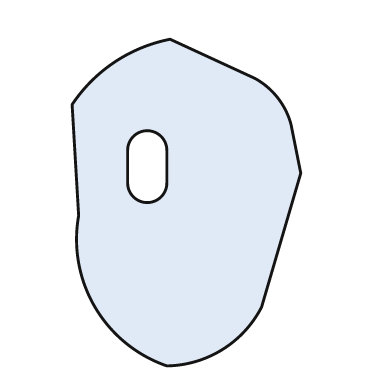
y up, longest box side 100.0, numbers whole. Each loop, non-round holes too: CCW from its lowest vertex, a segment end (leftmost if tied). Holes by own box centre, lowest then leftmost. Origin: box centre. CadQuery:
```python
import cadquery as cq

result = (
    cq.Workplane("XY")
    .moveTo(-6.0, -50.0)
    .threePointArc((11.0, -45.0), (23.0, -32.0))
    .lineTo(35.0, 9.0)
    .lineTo(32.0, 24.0)
    .threePointArc((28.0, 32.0), (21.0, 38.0))
    .lineTo(-5.0, 50.0)
    .threePointArc((-22.0, 43.0), (-35.0, 30.0))
    .lineTo(-33.0, -4.0)
    .threePointArc((-28.0, -32.0), (-6.0, -50.0))
    .close()
    .moveTo(-18.0, 6.0)
    .threePointArc((-12.0, 0.0), (-6.0, 6.0))
    .lineTo(-6.0, 16.0)
    .threePointArc((-12.0, 22.0), (-18.0, 16.0))
    .close()
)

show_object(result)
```